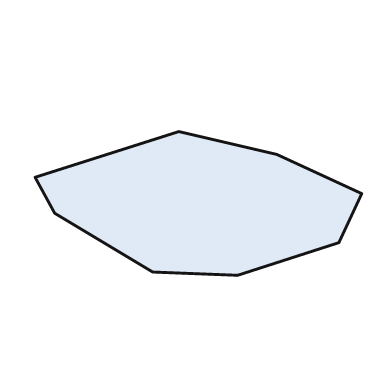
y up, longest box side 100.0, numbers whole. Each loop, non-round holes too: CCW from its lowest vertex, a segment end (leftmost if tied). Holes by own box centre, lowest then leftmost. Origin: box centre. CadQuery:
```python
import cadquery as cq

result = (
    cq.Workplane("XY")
    .moveTo(12.0, -22.0)
    .lineTo(43.0, -12.0)
    .lineTo(50.0, 3.0)
    .lineTo(24.0, 15.0)
    .lineTo(-6.0, 22.0)
    .lineTo(-50.0, 8.0)
    .lineTo(-44.0, -3.0)
    .lineTo(-14.0, -21.0)
    .close()
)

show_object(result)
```